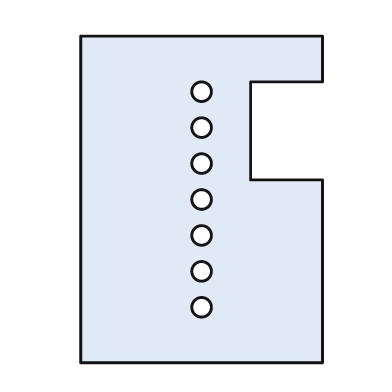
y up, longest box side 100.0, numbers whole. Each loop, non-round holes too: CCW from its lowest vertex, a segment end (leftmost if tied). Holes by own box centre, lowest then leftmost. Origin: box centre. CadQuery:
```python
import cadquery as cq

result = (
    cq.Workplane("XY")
    .moveTo(-37.0, -50.0)
    .lineTo(37.0, -50.0)
    .lineTo(37.0, 6.0)
    .lineTo(15.0, 6.0)
    .lineTo(15.0, 36.0)
    .lineTo(37.0, 36.0)
    .lineTo(37.0, 50.0)
    .lineTo(-37.0, 50.0)
    .close()
    .moveTo(0.0, -33.0)
    .circle(3.0)
    .moveTo(0.0, -22.0)
    .circle(3.0)
    .moveTo(0.0, -11.0)
    .circle(3.0)
    .moveTo(0.0, 0.0)
    .circle(3.0)
    .moveTo(0.0, 11.0)
    .circle(3.0)
    .moveTo(0.0, 22.0)
    .circle(3.0)
    .moveTo(0.0, 33.0)
    .circle(3.0)
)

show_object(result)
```